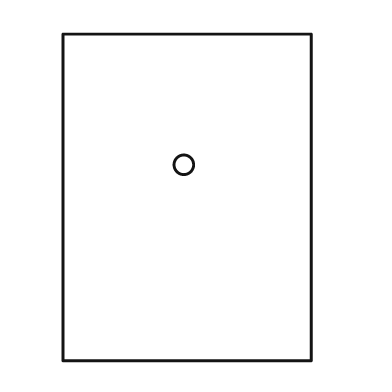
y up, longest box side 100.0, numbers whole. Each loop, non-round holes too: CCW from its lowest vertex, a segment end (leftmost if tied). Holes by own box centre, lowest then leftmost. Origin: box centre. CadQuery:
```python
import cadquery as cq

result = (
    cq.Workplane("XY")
    .moveTo(-38.0, -50.0)
    .lineTo(38.0, -50.0)
    .lineTo(38.0, 50.0)
    .lineTo(-38.0, 50.0)
    .close()
    .moveTo(-1.0, 10.0)
    .circle(3.0)
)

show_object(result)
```